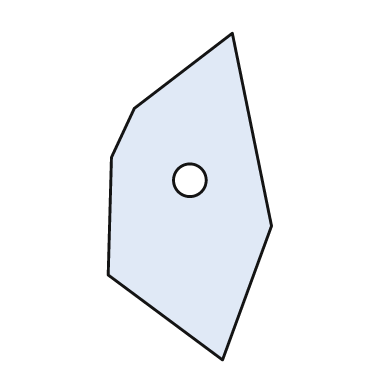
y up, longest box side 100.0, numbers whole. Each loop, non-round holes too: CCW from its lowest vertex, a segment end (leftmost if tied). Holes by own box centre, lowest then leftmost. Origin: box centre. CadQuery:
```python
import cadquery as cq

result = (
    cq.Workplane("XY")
    .moveTo(10.0, -50.0)
    .lineTo(25.0, -9.0)
    .lineTo(13.0, 50.0)
    .lineTo(-17.0, 27.0)
    .lineTo(-24.0, 12.0)
    .lineTo(-25.0, -24.0)
    .close()
    .moveTo(0.0, 5.0)
    .circle(5.0)
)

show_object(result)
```